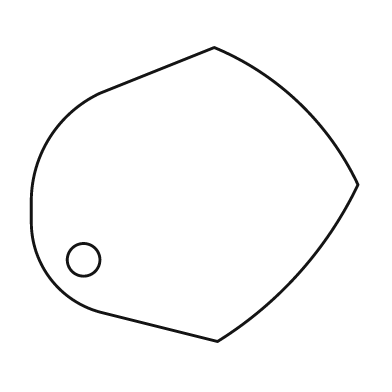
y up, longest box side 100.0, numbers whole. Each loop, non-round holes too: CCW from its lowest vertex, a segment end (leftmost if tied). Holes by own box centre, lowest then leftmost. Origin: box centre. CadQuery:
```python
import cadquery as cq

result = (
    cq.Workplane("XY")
    .moveTo(7.0, -45.0)
    .threePointArc((32.0, -24.0), (50.0, 3.0))
    .threePointArc((32.0, 28.0), (6.0, 45.0))
    .lineTo(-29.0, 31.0)
    .threePointArc((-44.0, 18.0), (-50.0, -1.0))
    .lineTo(-50.0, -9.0)
    .threePointArc((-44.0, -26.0), (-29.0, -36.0))
    .close()
    .moveTo(-34.0, -20.0)
    .circle(5.0)
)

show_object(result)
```